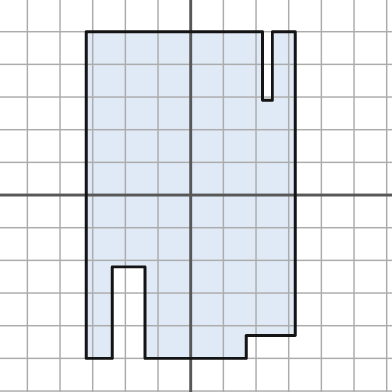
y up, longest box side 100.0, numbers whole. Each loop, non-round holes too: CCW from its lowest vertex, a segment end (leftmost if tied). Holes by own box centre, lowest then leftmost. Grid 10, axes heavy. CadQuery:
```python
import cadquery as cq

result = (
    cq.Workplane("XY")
    .moveTo(-32.0, -50.0)
    .lineTo(-24.0, -50.0)
    .lineTo(-24.0, -22.0)
    .lineTo(-14.0, -22.0)
    .lineTo(-14.0, -50.0)
    .lineTo(17.0, -50.0)
    .lineTo(17.0, -43.0)
    .lineTo(32.0, -43.0)
    .lineTo(32.0, 50.0)
    .lineTo(25.0, 50.0)
    .lineTo(25.0, 29.0)
    .lineTo(22.0, 29.0)
    .lineTo(22.0, 50.0)
    .lineTo(-32.0, 50.0)
    .close()
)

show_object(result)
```